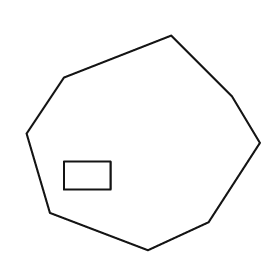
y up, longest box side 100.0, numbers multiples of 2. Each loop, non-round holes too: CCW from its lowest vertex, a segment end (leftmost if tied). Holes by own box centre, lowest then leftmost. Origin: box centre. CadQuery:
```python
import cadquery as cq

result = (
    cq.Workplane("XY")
    .moveTo(2.0, -46.0)
    .lineTo(28.0, -34.0)
    .lineTo(50.0, 0.0)
    .lineTo(38.0, 20.0)
    .lineTo(12.0, 46.0)
    .lineTo(-34.0, 28.0)
    .lineTo(-50.0, 4.0)
    .lineTo(-40.0, -30.0)
    .close()
    .moveTo(-34.0, -20.0)
    .lineTo(-14.0, -20.0)
    .lineTo(-14.0, -8.0)
    .lineTo(-34.0, -8.0)
    .close()
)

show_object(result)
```